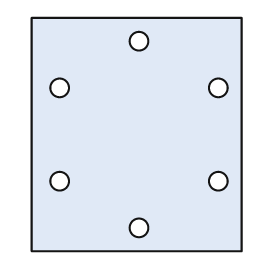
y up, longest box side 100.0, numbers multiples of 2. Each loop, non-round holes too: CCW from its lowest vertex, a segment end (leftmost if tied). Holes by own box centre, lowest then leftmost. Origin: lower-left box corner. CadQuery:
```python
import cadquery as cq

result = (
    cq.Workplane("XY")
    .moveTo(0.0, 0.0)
    .lineTo(90.0, 0.0)
    .lineTo(90.0, 100.0)
    .lineTo(0.0, 100.0)
    .close()
    .moveTo(46.0, 10.0)
    .circle(4.0)
    .moveTo(12.0, 30.0)
    .circle(4.0)
    .moveTo(80.0, 30.0)
    .circle(4.0)
    .moveTo(12.0, 70.0)
    .circle(4.0)
    .moveTo(80.0, 70.0)
    .circle(4.0)
    .moveTo(46.0, 90.0)
    .circle(4.0)
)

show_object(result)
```